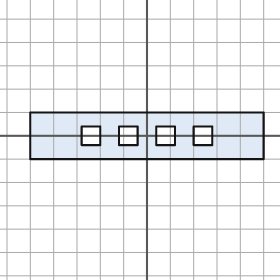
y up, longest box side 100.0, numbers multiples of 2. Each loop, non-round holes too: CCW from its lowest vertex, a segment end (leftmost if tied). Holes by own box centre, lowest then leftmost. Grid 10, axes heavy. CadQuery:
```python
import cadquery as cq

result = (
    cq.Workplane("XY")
    .moveTo(-50.0, -10.0)
    .lineTo(50.0, -10.0)
    .lineTo(50.0, 10.0)
    .lineTo(-50.0, 10.0)
    .close()
    .moveTo(-28.0, -4.0)
    .lineTo(-20.0, -4.0)
    .lineTo(-20.0, 4.0)
    .lineTo(-28.0, 4.0)
    .close()
    .moveTo(-12.0, -4.0)
    .lineTo(-4.0, -4.0)
    .lineTo(-4.0, 4.0)
    .lineTo(-12.0, 4.0)
    .close()
    .moveTo(4.0, -4.0)
    .lineTo(12.0, -4.0)
    .lineTo(12.0, 4.0)
    .lineTo(4.0, 4.0)
    .close()
    .moveTo(20.0, -4.0)
    .lineTo(28.0, -4.0)
    .lineTo(28.0, 4.0)
    .lineTo(20.0, 4.0)
    .close()
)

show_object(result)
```